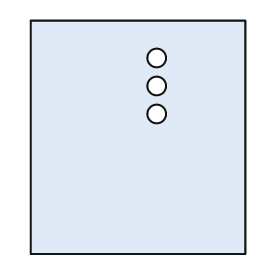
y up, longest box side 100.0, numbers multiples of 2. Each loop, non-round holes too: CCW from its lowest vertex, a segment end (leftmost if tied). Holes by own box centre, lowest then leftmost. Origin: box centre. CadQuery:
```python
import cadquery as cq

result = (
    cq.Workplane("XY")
    .moveTo(-46.0, -50.0)
    .lineTo(46.0, -50.0)
    .lineTo(46.0, 50.0)
    .lineTo(-46.0, 50.0)
    .close()
    .moveTo(8.0, 10.0)
    .circle(4.0)
    .moveTo(8.0, 22.0)
    .circle(4.0)
    .moveTo(8.0, 34.0)
    .circle(4.0)
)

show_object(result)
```